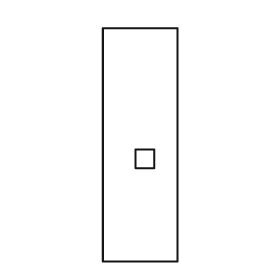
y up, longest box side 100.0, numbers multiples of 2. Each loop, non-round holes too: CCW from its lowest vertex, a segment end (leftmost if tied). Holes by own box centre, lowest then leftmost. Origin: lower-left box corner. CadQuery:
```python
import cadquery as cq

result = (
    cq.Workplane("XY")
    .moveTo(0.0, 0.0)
    .lineTo(32.0, 0.0)
    .lineTo(32.0, 100.0)
    .lineTo(0.0, 100.0)
    .close()
    .moveTo(14.0, 40.0)
    .lineTo(22.0, 40.0)
    .lineTo(22.0, 48.0)
    .lineTo(14.0, 48.0)
    .close()
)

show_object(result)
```